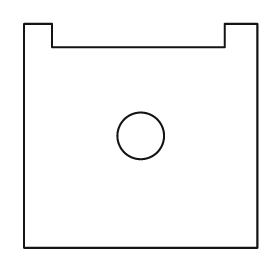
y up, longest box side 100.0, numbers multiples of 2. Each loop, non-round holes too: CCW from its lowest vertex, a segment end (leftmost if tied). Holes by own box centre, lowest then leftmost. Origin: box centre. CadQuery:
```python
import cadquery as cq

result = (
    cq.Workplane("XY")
    .moveTo(-50.0, -48.0)
    .lineTo(50.0, -48.0)
    .lineTo(50.0, 48.0)
    .lineTo(36.0, 48.0)
    .lineTo(36.0, 38.0)
    .lineTo(-38.0, 38.0)
    .lineTo(-38.0, 48.0)
    .lineTo(-50.0, 48.0)
    .close()
    .moveTo(0.0, 0.0)
    .circle(10.0)
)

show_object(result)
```